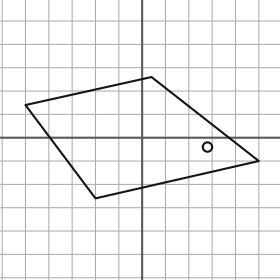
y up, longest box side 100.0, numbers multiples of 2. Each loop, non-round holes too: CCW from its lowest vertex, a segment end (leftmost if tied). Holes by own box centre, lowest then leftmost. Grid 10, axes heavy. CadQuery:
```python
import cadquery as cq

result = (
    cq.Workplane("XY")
    .moveTo(-20.0, -26.0)
    .lineTo(50.0, -10.0)
    .lineTo(4.0, 26.0)
    .lineTo(-50.0, 14.0)
    .close()
    .moveTo(28.0, -4.0)
    .circle(2.0)
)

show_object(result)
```